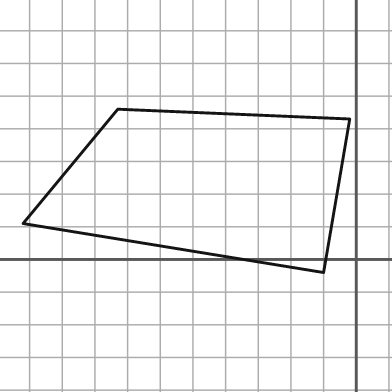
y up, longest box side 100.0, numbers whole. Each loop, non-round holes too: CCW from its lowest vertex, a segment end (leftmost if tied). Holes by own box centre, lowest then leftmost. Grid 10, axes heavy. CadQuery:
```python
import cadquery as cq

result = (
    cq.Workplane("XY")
    .moveTo(-10.0, -4.0)
    .lineTo(-2.0, 43.0)
    .lineTo(-73.0, 46.0)
    .lineTo(-102.0, 11.0)
    .close()
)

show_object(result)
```